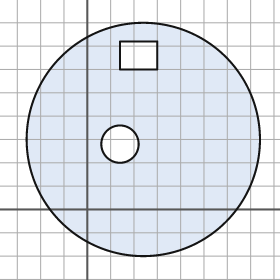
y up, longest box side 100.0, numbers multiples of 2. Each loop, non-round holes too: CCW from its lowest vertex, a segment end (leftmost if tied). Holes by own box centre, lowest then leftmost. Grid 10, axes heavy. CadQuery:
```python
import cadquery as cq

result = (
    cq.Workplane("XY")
    .moveTo(24.0, 30.0)
    .circle(50.0)
    .moveTo(14.0, 28.0)
    .circle(8.0)
    .moveTo(14.0, 60.0)
    .lineTo(30.0, 60.0)
    .lineTo(30.0, 72.0)
    .lineTo(14.0, 72.0)
    .close()
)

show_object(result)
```